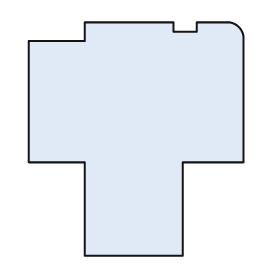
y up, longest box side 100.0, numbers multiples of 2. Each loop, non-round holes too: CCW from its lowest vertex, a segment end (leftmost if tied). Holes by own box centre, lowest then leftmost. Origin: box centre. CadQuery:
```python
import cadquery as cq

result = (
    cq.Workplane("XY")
    .moveTo(-22.0, -50.0)
    .lineTo(20.0, -50.0)
    .lineTo(20.0, -10.0)
    .lineTo(46.0, -10.0)
    .lineTo(46.0, 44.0)
    .threePointArc((44.0, 48.0), (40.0, 50.0))
    .lineTo(26.0, 50.0)
    .lineTo(26.0, 46.0)
    .lineTo(16.0, 46.0)
    .lineTo(16.0, 50.0)
    .lineTo(-22.0, 50.0)
    .lineTo(-22.0, 42.0)
    .lineTo(-46.0, 42.0)
    .lineTo(-46.0, -10.0)
    .lineTo(-22.0, -10.0)
    .close()
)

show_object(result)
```